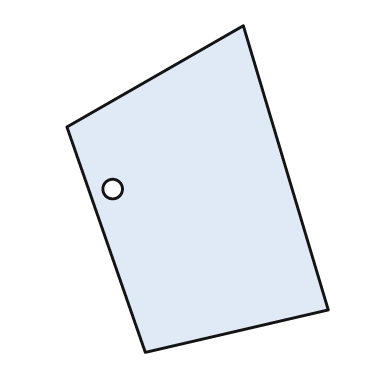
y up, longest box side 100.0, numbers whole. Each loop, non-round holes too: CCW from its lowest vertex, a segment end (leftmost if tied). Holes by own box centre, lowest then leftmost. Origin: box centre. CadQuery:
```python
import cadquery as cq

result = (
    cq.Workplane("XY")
    .moveTo(-16.0, -50.0)
    .lineTo(40.0, -37.0)
    .lineTo(14.0, 50.0)
    .lineTo(-40.0, 19.0)
    .close()
    .moveTo(-26.0, 0.0)
    .circle(3.0)
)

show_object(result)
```